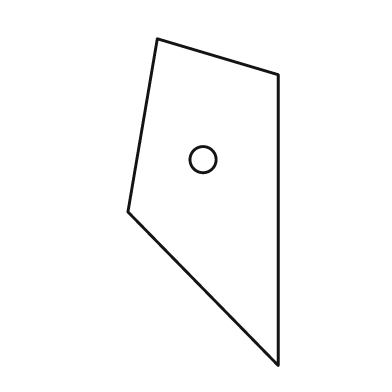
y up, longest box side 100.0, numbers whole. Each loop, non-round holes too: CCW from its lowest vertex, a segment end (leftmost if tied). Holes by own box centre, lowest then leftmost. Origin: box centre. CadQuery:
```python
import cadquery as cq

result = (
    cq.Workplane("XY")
    .moveTo(23.0, -50.0)
    .lineTo(23.0, 39.0)
    .lineTo(-14.0, 50.0)
    .lineTo(-23.0, -3.0)
    .close()
    .moveTo(0.0, 13.0)
    .circle(4.0)
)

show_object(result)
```